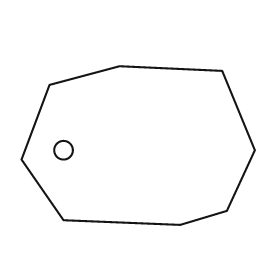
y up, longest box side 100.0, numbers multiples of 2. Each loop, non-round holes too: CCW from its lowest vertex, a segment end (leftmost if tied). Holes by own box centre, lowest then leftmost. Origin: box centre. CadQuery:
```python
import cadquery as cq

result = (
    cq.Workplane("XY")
    .moveTo(18.0, -34.0)
    .lineTo(38.0, -28.0)
    .lineTo(50.0, -2.0)
    .lineTo(36.0, 32.0)
    .lineTo(-8.0, 34.0)
    .lineTo(-38.0, 26.0)
    .lineTo(-50.0, -6.0)
    .lineTo(-32.0, -32.0)
    .close()
    .moveTo(-32.0, -2.0)
    .circle(4.0)
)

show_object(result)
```